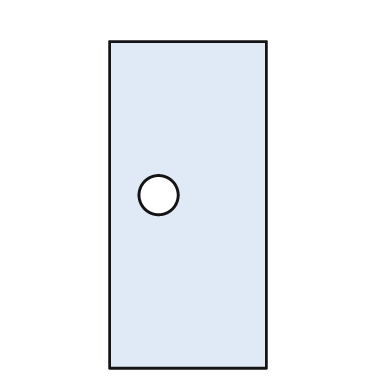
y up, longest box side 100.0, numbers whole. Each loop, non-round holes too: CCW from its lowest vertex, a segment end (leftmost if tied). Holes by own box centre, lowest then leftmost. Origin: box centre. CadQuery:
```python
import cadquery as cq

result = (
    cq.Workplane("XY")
    .moveTo(-24.0, -50.0)
    .lineTo(24.0, -50.0)
    .lineTo(24.0, 50.0)
    .lineTo(-24.0, 50.0)
    .close()
    .moveTo(-9.0, 3.0)
    .circle(6.0)
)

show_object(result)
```